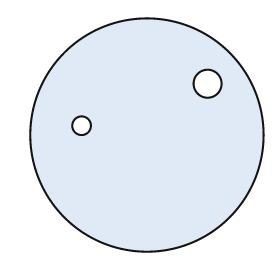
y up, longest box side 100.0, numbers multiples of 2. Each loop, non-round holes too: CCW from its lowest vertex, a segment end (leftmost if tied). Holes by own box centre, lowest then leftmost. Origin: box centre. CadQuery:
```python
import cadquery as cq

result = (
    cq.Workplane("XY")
    .moveTo(0.0, 0.0)
    .circle(50.0)
    .moveTo(-28.0, 4.0)
    .circle(4.0)
    .moveTo(26.0, 22.0)
    .circle(6.0)
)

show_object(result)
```